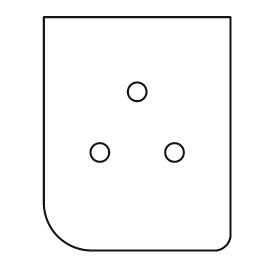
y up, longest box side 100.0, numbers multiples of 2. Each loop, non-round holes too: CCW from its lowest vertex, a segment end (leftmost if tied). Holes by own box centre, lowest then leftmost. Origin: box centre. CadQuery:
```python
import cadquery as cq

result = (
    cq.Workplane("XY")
    .moveTo(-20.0, -50.0)
    .lineTo(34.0, -50.0)
    .threePointArc((38.0, -48.0), (40.0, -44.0))
    .lineTo(40.0, 50.0)
    .lineTo(-40.0, 50.0)
    .lineTo(-40.0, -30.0)
    .threePointArc((-34.0, -44.0), (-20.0, -50.0))
    .close()
    .moveTo(-16.0, -8.0)
    .circle(4.0)
    .moveTo(16.0, -8.0)
    .circle(4.0)
    .moveTo(0.0, 18.0)
    .circle(4.0)
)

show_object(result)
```